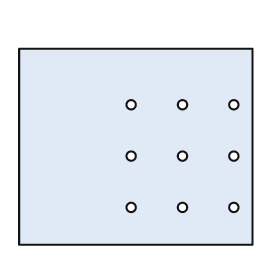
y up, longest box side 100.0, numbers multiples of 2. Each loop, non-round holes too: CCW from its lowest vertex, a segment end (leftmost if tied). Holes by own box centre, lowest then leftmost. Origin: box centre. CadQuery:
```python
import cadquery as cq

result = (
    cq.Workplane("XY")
    .moveTo(-50.0, -42.0)
    .lineTo(50.0, -42.0)
    .lineTo(50.0, 42.0)
    .lineTo(-50.0, 42.0)
    .close()
    .moveTo(-2.0, -26.0)
    .circle(2.0)
    .moveTo(20.0, -26.0)
    .circle(2.0)
    .moveTo(42.0, -26.0)
    .circle(2.0)
    .moveTo(-2.0, -4.0)
    .circle(2.0)
    .moveTo(20.0, -4.0)
    .circle(2.0)
    .moveTo(42.0, -4.0)
    .circle(2.0)
    .moveTo(-2.0, 18.0)
    .circle(2.0)
    .moveTo(20.0, 18.0)
    .circle(2.0)
    .moveTo(42.0, 18.0)
    .circle(2.0)
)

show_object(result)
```